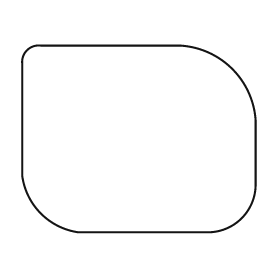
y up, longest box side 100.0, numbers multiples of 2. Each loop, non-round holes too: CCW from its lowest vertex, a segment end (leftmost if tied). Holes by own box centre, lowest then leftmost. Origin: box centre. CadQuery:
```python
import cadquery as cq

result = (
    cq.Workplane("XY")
    .moveTo(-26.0, -40.0)
    .lineTo(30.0, -40.0)
    .threePointArc((44.0, -34.0), (50.0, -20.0))
    .lineTo(50.0, 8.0)
    .threePointArc((40.0, 30.0), (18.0, 40.0))
    .lineTo(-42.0, 40.0)
    .threePointArc((-48.0, 38.0), (-50.0, 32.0))
    .lineTo(-50.0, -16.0)
    .threePointArc((-42.0, -32.0), (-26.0, -40.0))
    .close()
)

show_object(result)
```